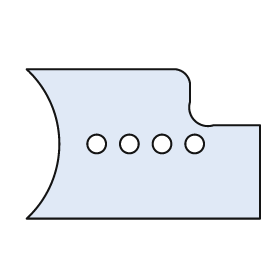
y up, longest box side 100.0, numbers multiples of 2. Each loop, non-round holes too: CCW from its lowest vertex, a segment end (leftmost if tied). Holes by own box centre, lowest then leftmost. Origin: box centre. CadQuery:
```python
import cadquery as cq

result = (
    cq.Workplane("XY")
    .moveTo(-50.0, -32.0)
    .lineTo(50.0, -32.0)
    .lineTo(50.0, 8.0)
    .lineTo(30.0, 8.0)
    .threePointArc((22.0, 10.0), (20.0, 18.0))
    .lineTo(20.0, 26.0)
    .threePointArc((18.0, 30.0), (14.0, 32.0))
    .lineTo(-50.0, 32.0)
    .threePointArc((-36.0, 0.0), (-50.0, -32.0))
    .close()
    .moveTo(-20.0, 0.0)
    .circle(4.0)
    .moveTo(-6.0, 0.0)
    .circle(4.0)
    .moveTo(8.0, 0.0)
    .circle(4.0)
    .moveTo(22.0, 0.0)
    .circle(4.0)
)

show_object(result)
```